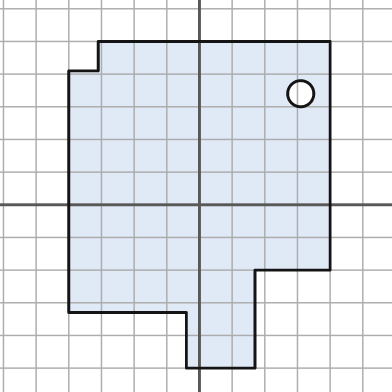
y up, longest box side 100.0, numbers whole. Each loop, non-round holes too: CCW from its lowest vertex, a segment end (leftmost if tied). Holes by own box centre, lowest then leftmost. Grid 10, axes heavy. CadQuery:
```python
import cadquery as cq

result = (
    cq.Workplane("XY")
    .moveTo(-4.0, -50.0)
    .lineTo(17.0, -50.0)
    .lineTo(17.0, -20.0)
    .lineTo(40.0, -20.0)
    .lineTo(40.0, 50.0)
    .lineTo(-31.0, 50.0)
    .lineTo(-31.0, 41.0)
    .lineTo(-40.0, 41.0)
    .lineTo(-40.0, -33.0)
    .lineTo(-4.0, -33.0)
    .close()
    .moveTo(31.0, 34.0)
    .circle(4.0)
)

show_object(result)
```